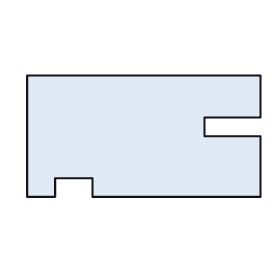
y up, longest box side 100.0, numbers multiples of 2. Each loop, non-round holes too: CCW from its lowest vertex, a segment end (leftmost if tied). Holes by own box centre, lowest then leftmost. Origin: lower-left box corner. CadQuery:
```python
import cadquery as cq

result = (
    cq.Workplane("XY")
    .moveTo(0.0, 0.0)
    .lineTo(12.0, 0.0)
    .lineTo(12.0, 8.0)
    .lineTo(28.0, 8.0)
    .lineTo(28.0, 0.0)
    .lineTo(100.0, 0.0)
    .lineTo(100.0, 26.0)
    .lineTo(76.0, 26.0)
    .lineTo(76.0, 34.0)
    .lineTo(100.0, 34.0)
    .lineTo(100.0, 52.0)
    .lineTo(0.0, 52.0)
    .close()
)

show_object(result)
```